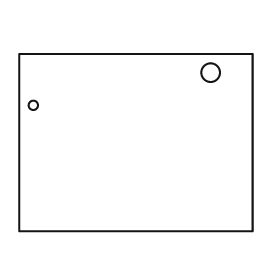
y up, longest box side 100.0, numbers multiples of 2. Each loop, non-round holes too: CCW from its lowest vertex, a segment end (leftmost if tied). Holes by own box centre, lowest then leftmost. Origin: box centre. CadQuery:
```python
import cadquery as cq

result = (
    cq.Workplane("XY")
    .moveTo(-50.0, -38.0)
    .lineTo(50.0, -38.0)
    .lineTo(50.0, 38.0)
    .lineTo(-50.0, 38.0)
    .close()
    .moveTo(-44.0, 16.0)
    .circle(2.0)
    .moveTo(32.0, 30.0)
    .circle(4.0)
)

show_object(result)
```